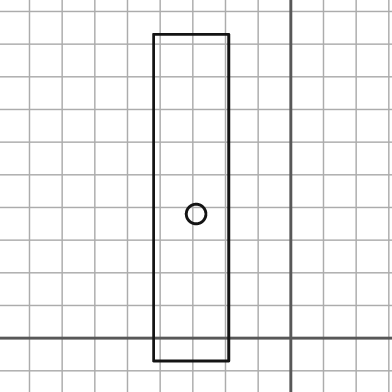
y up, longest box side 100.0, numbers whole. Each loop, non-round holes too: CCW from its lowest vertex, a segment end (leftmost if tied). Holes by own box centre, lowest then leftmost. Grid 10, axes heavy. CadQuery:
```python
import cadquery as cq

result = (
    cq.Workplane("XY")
    .moveTo(-42.0, -7.0)
    .lineTo(-19.0, -7.0)
    .lineTo(-19.0, 93.0)
    .lineTo(-42.0, 93.0)
    .close()
    .moveTo(-29.0, 38.0)
    .circle(3.0)
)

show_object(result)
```